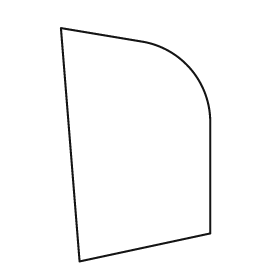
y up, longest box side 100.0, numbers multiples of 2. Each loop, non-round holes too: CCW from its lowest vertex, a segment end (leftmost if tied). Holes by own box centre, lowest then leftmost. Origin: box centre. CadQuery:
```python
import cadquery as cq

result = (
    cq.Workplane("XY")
    .moveTo(-24.0, -50.0)
    .lineTo(32.0, -38.0)
    .lineTo(32.0, 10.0)
    .threePointArc((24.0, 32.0), (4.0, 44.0))
    .lineTo(-32.0, 50.0)
    .close()
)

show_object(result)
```